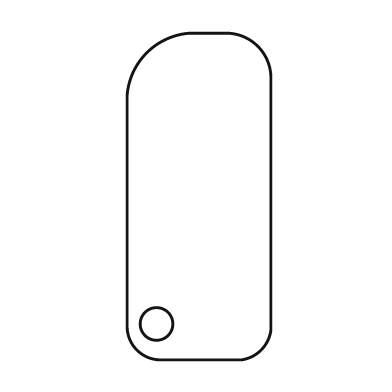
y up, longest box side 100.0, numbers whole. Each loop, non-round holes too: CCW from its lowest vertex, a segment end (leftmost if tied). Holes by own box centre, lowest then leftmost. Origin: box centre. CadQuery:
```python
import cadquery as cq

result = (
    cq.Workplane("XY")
    .moveTo(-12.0, -50.0)
    .lineTo(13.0, -50.0)
    .threePointArc((19.0, -47.0), (22.0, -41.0))
    .lineTo(22.0, 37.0)
    .threePointArc((18.0, 46.0), (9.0, 50.0))
    .lineTo(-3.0, 50.0)
    .threePointArc((-16.0, 44.0), (-22.0, 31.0))
    .lineTo(-22.0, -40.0)
    .threePointArc((-19.0, -47.0), (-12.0, -50.0))
    .close()
    .moveTo(-13.0, -39.0)
    .circle(5.0)
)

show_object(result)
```